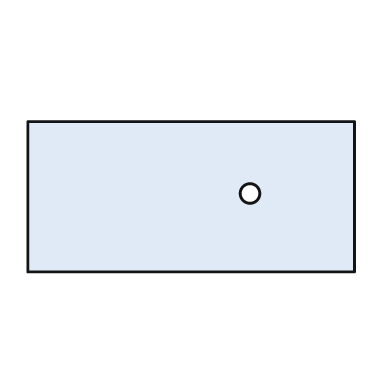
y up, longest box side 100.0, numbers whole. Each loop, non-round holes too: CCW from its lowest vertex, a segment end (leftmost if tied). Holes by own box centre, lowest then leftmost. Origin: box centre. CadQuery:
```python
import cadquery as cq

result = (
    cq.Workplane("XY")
    .moveTo(-50.0, -23.0)
    .lineTo(50.0, -23.0)
    .lineTo(50.0, 23.0)
    .lineTo(-50.0, 23.0)
    .close()
    .moveTo(18.0, 1.0)
    .circle(3.0)
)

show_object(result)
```